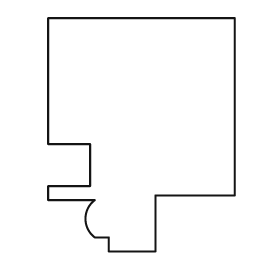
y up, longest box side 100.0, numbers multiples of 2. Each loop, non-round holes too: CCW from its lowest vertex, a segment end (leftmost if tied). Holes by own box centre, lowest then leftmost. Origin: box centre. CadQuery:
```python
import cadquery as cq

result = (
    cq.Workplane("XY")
    .moveTo(-14.0, -50.0)
    .lineTo(6.0, -50.0)
    .lineTo(6.0, -26.0)
    .lineTo(40.0, -26.0)
    .lineTo(40.0, 50.0)
    .lineTo(-40.0, 50.0)
    .lineTo(-40.0, -4.0)
    .lineTo(-22.0, -4.0)
    .lineTo(-22.0, -22.0)
    .lineTo(-40.0, -22.0)
    .lineTo(-40.0, -28.0)
    .lineTo(-20.0, -28.0)
    .threePointArc((-24.0, -36.0), (-20.0, -44.0))
    .lineTo(-14.0, -44.0)
    .close()
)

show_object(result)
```